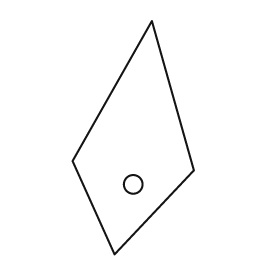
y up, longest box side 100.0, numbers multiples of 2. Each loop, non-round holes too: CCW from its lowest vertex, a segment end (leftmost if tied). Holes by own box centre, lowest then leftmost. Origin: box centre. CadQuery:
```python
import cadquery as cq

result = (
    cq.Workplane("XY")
    .moveTo(-8.0, -50.0)
    .lineTo(26.0, -14.0)
    .lineTo(8.0, 50.0)
    .lineTo(-26.0, -10.0)
    .close()
    .moveTo(0.0, -20.0)
    .circle(4.0)
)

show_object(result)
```